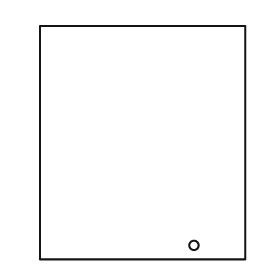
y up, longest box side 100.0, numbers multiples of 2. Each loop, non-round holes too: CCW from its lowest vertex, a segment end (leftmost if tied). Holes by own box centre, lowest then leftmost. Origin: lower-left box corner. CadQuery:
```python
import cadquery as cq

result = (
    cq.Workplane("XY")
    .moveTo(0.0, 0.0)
    .lineTo(88.0, 0.0)
    .lineTo(88.0, 100.0)
    .lineTo(0.0, 100.0)
    .close()
    .moveTo(66.0, 6.0)
    .circle(2.0)
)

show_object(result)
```